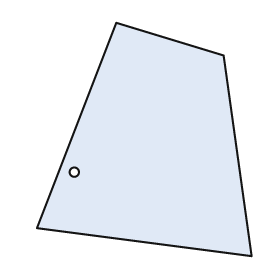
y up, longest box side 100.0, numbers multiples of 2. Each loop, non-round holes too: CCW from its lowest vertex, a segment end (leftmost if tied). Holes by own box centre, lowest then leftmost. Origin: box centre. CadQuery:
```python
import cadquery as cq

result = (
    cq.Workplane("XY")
    .moveTo(46.0, -50.0)
    .lineTo(34.0, 36.0)
    .lineTo(-12.0, 50.0)
    .lineTo(-46.0, -38.0)
    .close()
    .moveTo(-30.0, -14.0)
    .circle(2.0)
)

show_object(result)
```